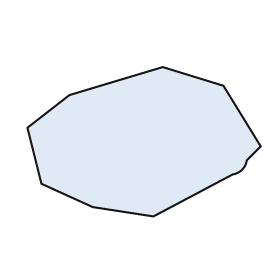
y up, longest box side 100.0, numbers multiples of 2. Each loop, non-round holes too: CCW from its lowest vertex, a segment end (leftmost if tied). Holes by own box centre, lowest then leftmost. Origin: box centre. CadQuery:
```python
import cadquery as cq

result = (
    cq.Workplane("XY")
    .moveTo(4.0, -32.0)
    .lineTo(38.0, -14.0)
    .threePointArc((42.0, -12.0), (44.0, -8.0))
    .lineTo(50.0, -2.0)
    .lineTo(34.0, 24.0)
    .lineTo(8.0, 32.0)
    .lineTo(-32.0, 20.0)
    .lineTo(-50.0, 6.0)
    .lineTo(-44.0, -18.0)
    .lineTo(-22.0, -28.0)
    .close()
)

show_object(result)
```